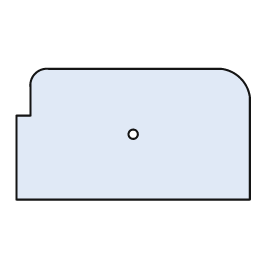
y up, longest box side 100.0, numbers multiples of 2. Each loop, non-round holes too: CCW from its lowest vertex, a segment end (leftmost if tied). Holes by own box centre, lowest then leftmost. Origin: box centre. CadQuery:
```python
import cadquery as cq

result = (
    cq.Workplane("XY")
    .moveTo(-50.0, -28.0)
    .lineTo(50.0, -28.0)
    .lineTo(50.0, 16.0)
    .threePointArc((46.0, 24.0), (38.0, 28.0))
    .lineTo(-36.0, 28.0)
    .threePointArc((-42.0, 26.0), (-44.0, 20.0))
    .lineTo(-44.0, 8.0)
    .lineTo(-50.0, 8.0)
    .close()
    .moveTo(0.0, 0.0)
    .circle(2.0)
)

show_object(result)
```